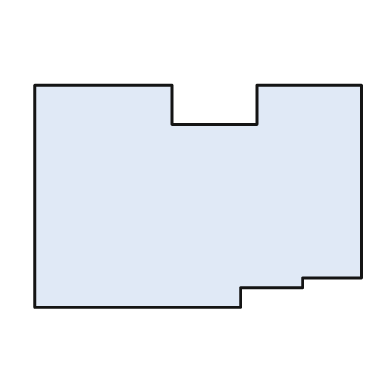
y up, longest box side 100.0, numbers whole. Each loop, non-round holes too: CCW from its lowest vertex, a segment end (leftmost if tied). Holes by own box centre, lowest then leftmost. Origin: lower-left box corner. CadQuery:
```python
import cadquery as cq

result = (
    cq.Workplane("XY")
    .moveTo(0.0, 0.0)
    .lineTo(63.0, 0.0)
    .lineTo(63.0, 6.0)
    .lineTo(82.0, 6.0)
    .lineTo(82.0, 9.0)
    .lineTo(100.0, 9.0)
    .lineTo(100.0, 68.0)
    .lineTo(68.0, 68.0)
    .lineTo(68.0, 56.0)
    .lineTo(42.0, 56.0)
    .lineTo(42.0, 68.0)
    .lineTo(0.0, 68.0)
    .close()
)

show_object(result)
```